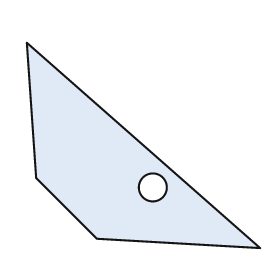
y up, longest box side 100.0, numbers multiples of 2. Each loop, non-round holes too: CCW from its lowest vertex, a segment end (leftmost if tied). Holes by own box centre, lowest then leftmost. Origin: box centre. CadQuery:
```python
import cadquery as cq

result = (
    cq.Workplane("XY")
    .moveTo(50.0, -44.0)
    .lineTo(-50.0, 44.0)
    .lineTo(-46.0, -14.0)
    .lineTo(-20.0, -40.0)
    .close()
    .moveTo(4.0, -18.0)
    .circle(6.0)
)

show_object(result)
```